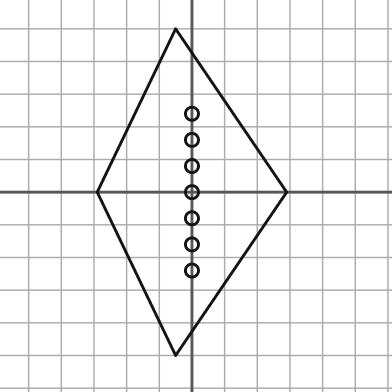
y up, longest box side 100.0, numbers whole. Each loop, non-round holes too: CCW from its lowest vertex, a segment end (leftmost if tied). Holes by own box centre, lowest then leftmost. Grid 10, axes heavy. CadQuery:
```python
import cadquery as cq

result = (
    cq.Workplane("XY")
    .moveTo(-5.0, -50.0)
    .lineTo(29.0, 0.0)
    .lineTo(-5.0, 50.0)
    .lineTo(-29.0, 0.0)
    .close()
    .moveTo(0.0, -24.0)
    .circle(2.0)
    .moveTo(0.0, -16.0)
    .circle(2.0)
    .moveTo(0.0, -8.0)
    .circle(2.0)
    .moveTo(0.0, 0.0)
    .circle(2.0)
    .moveTo(0.0, 8.0)
    .circle(2.0)
    .moveTo(0.0, 16.0)
    .circle(2.0)
    .moveTo(0.0, 24.0)
    .circle(2.0)
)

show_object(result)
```